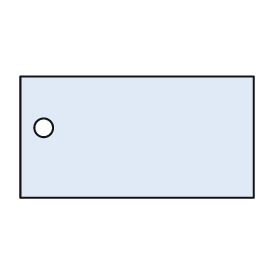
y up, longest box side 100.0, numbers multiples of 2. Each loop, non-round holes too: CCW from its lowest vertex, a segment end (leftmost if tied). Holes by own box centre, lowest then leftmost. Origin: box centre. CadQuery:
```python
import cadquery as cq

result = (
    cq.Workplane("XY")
    .moveTo(-50.0, -26.0)
    .lineTo(50.0, -26.0)
    .lineTo(50.0, 26.0)
    .lineTo(-50.0, 26.0)
    .close()
    .moveTo(-40.0, 4.0)
    .circle(4.0)
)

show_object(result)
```